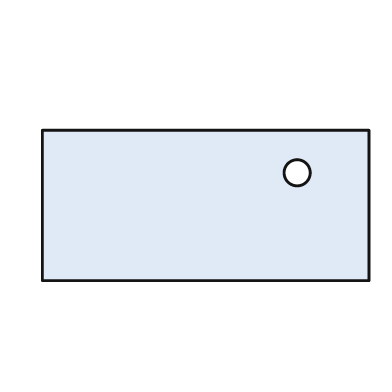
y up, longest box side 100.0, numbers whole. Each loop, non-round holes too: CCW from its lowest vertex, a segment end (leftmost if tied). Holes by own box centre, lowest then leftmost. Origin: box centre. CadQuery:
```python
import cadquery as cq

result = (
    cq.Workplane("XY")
    .moveTo(-50.0, -23.0)
    .lineTo(50.0, -23.0)
    .lineTo(50.0, 23.0)
    .lineTo(-50.0, 23.0)
    .close()
    .moveTo(28.0, 10.0)
    .circle(4.0)
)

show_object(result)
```